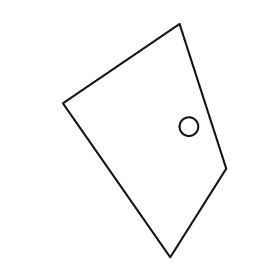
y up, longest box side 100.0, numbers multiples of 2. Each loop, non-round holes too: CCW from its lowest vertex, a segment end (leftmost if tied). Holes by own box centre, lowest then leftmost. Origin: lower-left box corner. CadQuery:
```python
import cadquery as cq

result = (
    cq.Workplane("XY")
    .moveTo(46.0, 0.0)
    .lineTo(70.0, 38.0)
    .lineTo(50.0, 100.0)
    .lineTo(0.0, 66.0)
    .close()
    .moveTo(54.0, 56.0)
    .circle(4.0)
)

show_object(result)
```